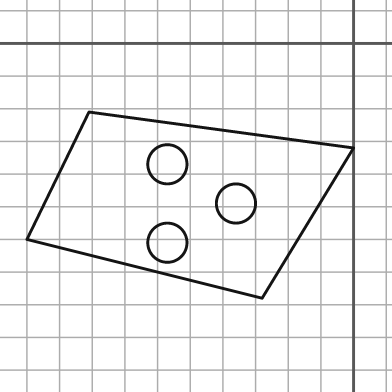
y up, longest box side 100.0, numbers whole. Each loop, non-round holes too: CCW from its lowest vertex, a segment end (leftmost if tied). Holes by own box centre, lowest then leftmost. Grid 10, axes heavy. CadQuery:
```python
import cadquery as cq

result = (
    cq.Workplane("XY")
    .moveTo(-28.0, -78.0)
    .lineTo(0.0, -32.0)
    .lineTo(-81.0, -21.0)
    .lineTo(-100.0, -60.0)
    .close()
    .moveTo(-57.0, -61.0)
    .circle(6.0)
    .moveTo(-36.0, -49.0)
    .circle(6.0)
    .moveTo(-57.0, -37.0)
    .circle(6.0)
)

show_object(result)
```